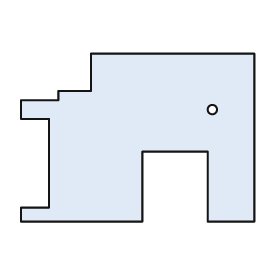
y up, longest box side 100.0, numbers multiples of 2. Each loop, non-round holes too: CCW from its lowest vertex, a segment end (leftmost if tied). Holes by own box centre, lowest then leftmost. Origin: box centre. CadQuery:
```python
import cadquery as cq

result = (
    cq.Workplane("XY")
    .moveTo(-50.0, -36.0)
    .lineTo(2.0, -36.0)
    .lineTo(2.0, -6.0)
    .lineTo(30.0, -6.0)
    .lineTo(30.0, -36.0)
    .lineTo(50.0, -36.0)
    .lineTo(50.0, 36.0)
    .lineTo(-20.0, 36.0)
    .lineTo(-20.0, 20.0)
    .lineTo(-34.0, 20.0)
    .lineTo(-34.0, 16.0)
    .lineTo(-50.0, 16.0)
    .lineTo(-50.0, 8.0)
    .lineTo(-38.0, 8.0)
    .lineTo(-38.0, -30.0)
    .lineTo(-50.0, -30.0)
    .close()
    .moveTo(32.0, 12.0)
    .circle(2.0)
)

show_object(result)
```